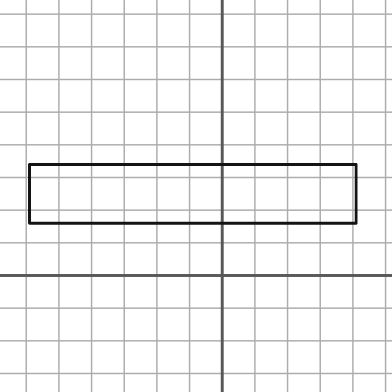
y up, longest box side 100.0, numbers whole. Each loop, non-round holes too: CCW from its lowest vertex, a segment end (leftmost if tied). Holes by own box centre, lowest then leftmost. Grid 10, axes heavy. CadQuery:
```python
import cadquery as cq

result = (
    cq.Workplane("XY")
    .moveTo(-59.0, 16.0)
    .lineTo(41.0, 16.0)
    .lineTo(41.0, 34.0)
    .lineTo(-59.0, 34.0)
    .close()
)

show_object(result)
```